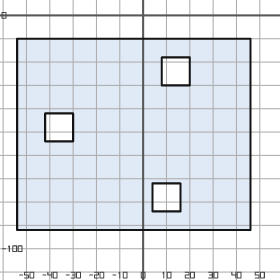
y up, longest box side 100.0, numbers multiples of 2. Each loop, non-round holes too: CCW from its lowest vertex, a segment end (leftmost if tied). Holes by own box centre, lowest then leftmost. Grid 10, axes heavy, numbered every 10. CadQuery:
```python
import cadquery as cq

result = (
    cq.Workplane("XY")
    .moveTo(-54.0, -92.0)
    .lineTo(46.0, -92.0)
    .lineTo(46.0, -10.0)
    .lineTo(-54.0, -10.0)
    .close()
    .moveTo(4.0, -84.0)
    .lineTo(16.0, -84.0)
    .lineTo(16.0, -72.0)
    .lineTo(4.0, -72.0)
    .close()
    .moveTo(-42.0, -54.0)
    .lineTo(-30.0, -54.0)
    .lineTo(-30.0, -42.0)
    .lineTo(-42.0, -42.0)
    .close()
    .moveTo(8.0, -30.0)
    .lineTo(20.0, -30.0)
    .lineTo(20.0, -18.0)
    .lineTo(8.0, -18.0)
    .close()
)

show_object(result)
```